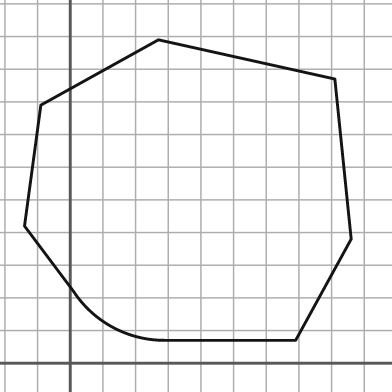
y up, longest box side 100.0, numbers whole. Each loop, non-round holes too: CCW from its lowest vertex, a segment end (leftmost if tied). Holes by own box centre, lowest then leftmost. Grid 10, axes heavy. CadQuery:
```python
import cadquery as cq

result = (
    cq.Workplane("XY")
    .moveTo(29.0, 7.0)
    .lineTo(69.0, 7.0)
    .lineTo(86.0, 38.0)
    .lineTo(81.0, 87.0)
    .lineTo(27.0, 99.0)
    .lineTo(-9.0, 79.0)
    .lineTo(-14.0, 42.0)
    .lineTo(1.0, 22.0)
    .threePointArc((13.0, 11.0), (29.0, 7.0))
    .close()
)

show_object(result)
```